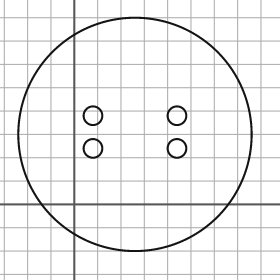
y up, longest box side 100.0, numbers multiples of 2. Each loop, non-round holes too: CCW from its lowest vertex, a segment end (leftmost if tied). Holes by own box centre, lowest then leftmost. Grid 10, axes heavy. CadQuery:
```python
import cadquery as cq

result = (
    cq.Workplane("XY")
    .moveTo(26.0, 30.0)
    .circle(50.0)
    .moveTo(8.0, 24.0)
    .circle(4.0)
    .moveTo(44.0, 24.0)
    .circle(4.0)
    .moveTo(8.0, 38.0)
    .circle(4.0)
    .moveTo(44.0, 38.0)
    .circle(4.0)
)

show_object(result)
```